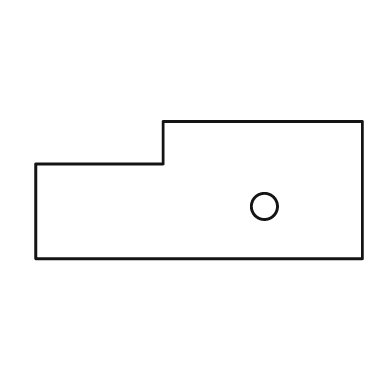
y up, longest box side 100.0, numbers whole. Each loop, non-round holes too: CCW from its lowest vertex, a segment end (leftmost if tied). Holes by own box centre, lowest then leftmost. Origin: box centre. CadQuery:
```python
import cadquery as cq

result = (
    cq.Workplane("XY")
    .moveTo(-50.0, -21.0)
    .lineTo(50.0, -21.0)
    .lineTo(50.0, 21.0)
    .lineTo(-11.0, 21.0)
    .lineTo(-11.0, 8.0)
    .lineTo(-50.0, 8.0)
    .close()
    .moveTo(20.0, -5.0)
    .circle(4.0)
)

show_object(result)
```